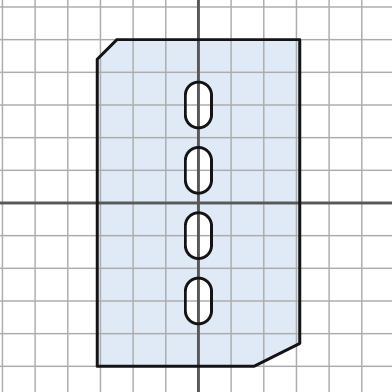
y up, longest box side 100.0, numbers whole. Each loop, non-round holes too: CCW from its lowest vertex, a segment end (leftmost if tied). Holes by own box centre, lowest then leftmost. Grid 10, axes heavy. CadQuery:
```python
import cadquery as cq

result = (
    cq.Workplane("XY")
    .moveTo(-31.0, -50.0)
    .lineTo(17.0, -50.0)
    .lineTo(31.0, -43.0)
    .lineTo(31.0, 50.0)
    .lineTo(-25.0, 50.0)
    .lineTo(-31.0, 44.0)
    .close()
    .moveTo(-4.0, -33.0)
    .threePointArc((0.0, -37.0), (4.0, -33.0))
    .lineTo(4.0, -27.0)
    .threePointArc((0.0, -23.0), (-4.0, -27.0))
    .close()
    .moveTo(-4.0, -13.0)
    .threePointArc((0.0, -17.0), (4.0, -13.0))
    .lineTo(4.0, -7.0)
    .threePointArc((0.0, -3.0), (-4.0, -7.0))
    .close()
    .moveTo(-4.0, 7.0)
    .threePointArc((0.0, 3.0), (4.0, 7.0))
    .lineTo(4.0, 13.0)
    .threePointArc((0.0, 17.0), (-4.0, 13.0))
    .close()
    .moveTo(-4.0, 27.0)
    .threePointArc((0.0, 23.0), (4.0, 27.0))
    .lineTo(4.0, 33.0)
    .threePointArc((0.0, 37.0), (-4.0, 33.0))
    .close()
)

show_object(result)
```